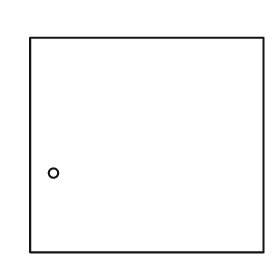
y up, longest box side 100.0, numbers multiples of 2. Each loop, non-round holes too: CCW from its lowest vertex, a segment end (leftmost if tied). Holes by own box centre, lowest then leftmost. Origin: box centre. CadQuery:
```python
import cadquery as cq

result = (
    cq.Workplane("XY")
    .moveTo(-50.0, -46.0)
    .lineTo(50.0, -46.0)
    .lineTo(50.0, 46.0)
    .lineTo(-50.0, 46.0)
    .close()
    .moveTo(-40.0, -12.0)
    .circle(2.0)
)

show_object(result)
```